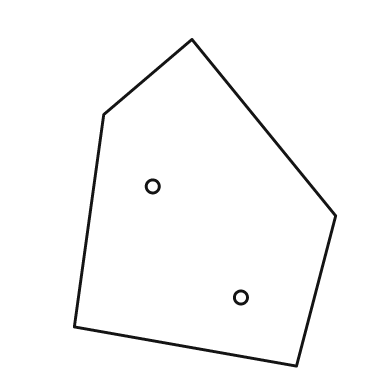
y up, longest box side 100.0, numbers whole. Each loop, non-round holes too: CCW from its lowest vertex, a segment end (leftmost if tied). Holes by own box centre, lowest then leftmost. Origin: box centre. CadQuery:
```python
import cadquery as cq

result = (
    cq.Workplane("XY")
    .moveTo(28.0, -50.0)
    .lineTo(40.0, -4.0)
    .lineTo(-4.0, 50.0)
    .lineTo(-31.0, 27.0)
    .lineTo(-40.0, -38.0)
    .close()
    .moveTo(11.0, -29.0)
    .circle(2.0)
    .moveTo(-16.0, 5.0)
    .circle(2.0)
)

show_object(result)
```